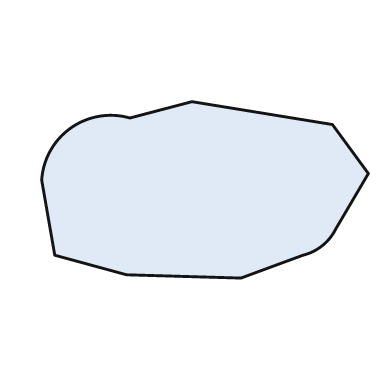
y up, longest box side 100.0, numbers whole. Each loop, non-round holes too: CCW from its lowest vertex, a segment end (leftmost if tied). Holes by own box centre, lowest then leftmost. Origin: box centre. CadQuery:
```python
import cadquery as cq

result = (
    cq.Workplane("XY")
    .moveTo(11.0, -27.0)
    .lineTo(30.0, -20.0)
    .threePointArc((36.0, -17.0), (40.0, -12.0))
    .lineTo(50.0, 5.0)
    .lineTo(39.0, 20.0)
    .lineTo(-4.0, 27.0)
    .lineTo(-23.0, 22.0)
    .threePointArc((-41.0, 19.0), (-50.0, 3.0))
    .lineTo(-46.0, -20.0)
    .lineTo(-24.0, -26.0)
    .close()
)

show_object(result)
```